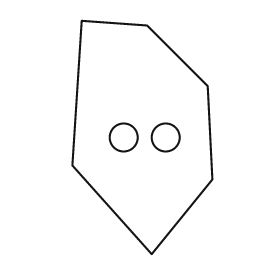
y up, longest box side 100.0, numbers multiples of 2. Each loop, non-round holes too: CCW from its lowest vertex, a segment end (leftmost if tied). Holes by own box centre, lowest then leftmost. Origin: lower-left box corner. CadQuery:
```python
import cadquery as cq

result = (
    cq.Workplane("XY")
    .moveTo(34.0, 0.0)
    .lineTo(60.0, 32.0)
    .lineTo(58.0, 72.0)
    .lineTo(32.0, 98.0)
    .lineTo(4.0, 100.0)
    .lineTo(0.0, 38.0)
    .close()
    .moveTo(22.0, 50.0)
    .circle(6.0)
    .moveTo(40.0, 50.0)
    .circle(6.0)
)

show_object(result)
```